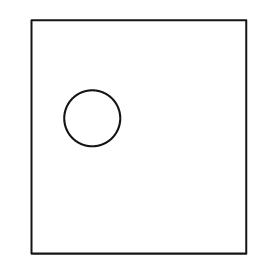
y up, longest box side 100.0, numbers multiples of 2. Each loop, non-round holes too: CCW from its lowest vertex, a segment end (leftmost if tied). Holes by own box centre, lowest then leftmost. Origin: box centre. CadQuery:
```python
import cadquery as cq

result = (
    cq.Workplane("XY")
    .moveTo(-46.0, -50.0)
    .lineTo(46.0, -50.0)
    .lineTo(46.0, 50.0)
    .lineTo(-46.0, 50.0)
    .close()
    .moveTo(-20.0, 8.0)
    .circle(12.0)
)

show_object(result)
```